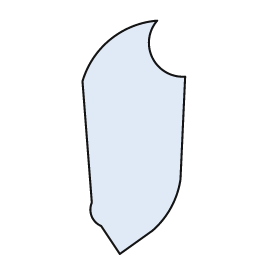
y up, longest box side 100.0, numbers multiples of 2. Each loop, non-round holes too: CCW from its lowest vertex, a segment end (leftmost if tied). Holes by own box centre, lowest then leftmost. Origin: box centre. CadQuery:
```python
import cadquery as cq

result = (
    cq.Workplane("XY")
    .moveTo(-6.0, -50.0)
    .lineTo(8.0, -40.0)
    .threePointArc((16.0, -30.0), (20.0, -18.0))
    .lineTo(22.0, 26.0)
    .threePointArc((8.0, 34.0), (10.0, 50.0))
    .threePointArc((-10.0, 42.0), (-22.0, 24.0))
    .lineTo(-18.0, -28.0)
    .threePointArc((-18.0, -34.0), (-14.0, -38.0))
    .close()
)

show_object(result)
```